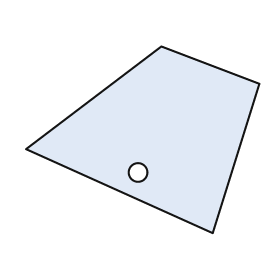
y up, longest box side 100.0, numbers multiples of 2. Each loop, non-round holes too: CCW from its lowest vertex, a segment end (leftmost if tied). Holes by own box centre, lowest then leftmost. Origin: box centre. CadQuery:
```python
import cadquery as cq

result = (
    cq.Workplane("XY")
    .moveTo(30.0, -40.0)
    .lineTo(50.0, 24.0)
    .lineTo(8.0, 40.0)
    .lineTo(-50.0, -4.0)
    .close()
    .moveTo(-2.0, -14.0)
    .circle(4.0)
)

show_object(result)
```